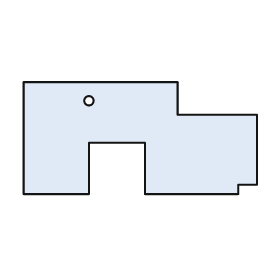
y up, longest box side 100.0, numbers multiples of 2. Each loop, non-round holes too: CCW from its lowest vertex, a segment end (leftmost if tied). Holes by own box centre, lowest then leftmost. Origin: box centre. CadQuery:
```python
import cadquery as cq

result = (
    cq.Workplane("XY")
    .moveTo(-50.0, -24.0)
    .lineTo(-22.0, -24.0)
    .lineTo(-22.0, -2.0)
    .lineTo(2.0, -2.0)
    .lineTo(2.0, -24.0)
    .lineTo(42.0, -24.0)
    .lineTo(42.0, -20.0)
    .lineTo(50.0, -20.0)
    .lineTo(50.0, 10.0)
    .lineTo(16.0, 10.0)
    .lineTo(16.0, 24.0)
    .lineTo(-50.0, 24.0)
    .close()
    .moveTo(-22.0, 16.0)
    .circle(2.0)
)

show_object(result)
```